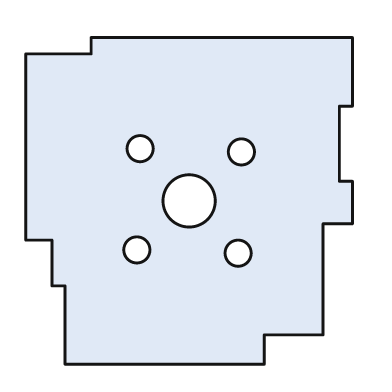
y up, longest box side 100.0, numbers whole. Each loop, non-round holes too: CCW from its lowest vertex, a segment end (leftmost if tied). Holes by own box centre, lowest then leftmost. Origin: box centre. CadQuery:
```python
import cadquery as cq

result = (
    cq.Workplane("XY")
    .moveTo(-38.0, -50.0)
    .lineTo(23.0, -50.0)
    .lineTo(23.0, -41.0)
    .lineTo(41.0, -41.0)
    .lineTo(41.0, -7.0)
    .lineTo(50.0, -7.0)
    .lineTo(50.0, 6.0)
    .lineTo(46.0, 6.0)
    .lineTo(46.0, 29.0)
    .lineTo(50.0, 29.0)
    .lineTo(50.0, 50.0)
    .lineTo(-30.0, 50.0)
    .lineTo(-30.0, 45.0)
    .lineTo(-50.0, 45.0)
    .lineTo(-50.0, -12.0)
    .lineTo(-42.0, -12.0)
    .lineTo(-42.0, -26.0)
    .lineTo(-38.0, -26.0)
    .close()
    .moveTo(15.0, -16.0)
    .circle(4.0)
    .moveTo(-16.0, -15.0)
    .circle(4.0)
    .moveTo(0.0, 0.0)
    .circle(8.0)
    .moveTo(16.0, 15.0)
    .circle(4.0)
    .moveTo(-15.0, 16.0)
    .circle(4.0)
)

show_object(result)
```